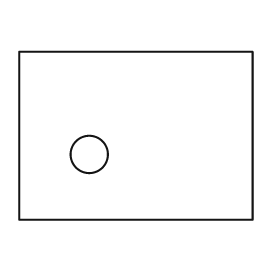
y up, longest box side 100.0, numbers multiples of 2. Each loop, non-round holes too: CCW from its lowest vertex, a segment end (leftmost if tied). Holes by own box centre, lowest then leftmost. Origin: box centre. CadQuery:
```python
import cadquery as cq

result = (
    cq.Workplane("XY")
    .moveTo(-50.0, -36.0)
    .lineTo(50.0, -36.0)
    .lineTo(50.0, 36.0)
    .lineTo(-50.0, 36.0)
    .close()
    .moveTo(-20.0, -8.0)
    .circle(8.0)
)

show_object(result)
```